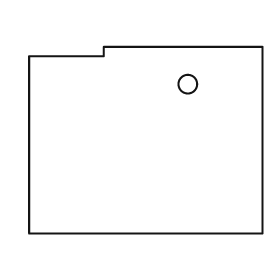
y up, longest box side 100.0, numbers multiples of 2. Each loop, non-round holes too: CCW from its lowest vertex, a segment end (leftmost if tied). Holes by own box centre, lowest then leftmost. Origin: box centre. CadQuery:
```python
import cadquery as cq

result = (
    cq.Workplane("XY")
    .moveTo(-50.0, -40.0)
    .lineTo(50.0, -40.0)
    .lineTo(50.0, 40.0)
    .lineTo(-18.0, 40.0)
    .lineTo(-18.0, 36.0)
    .lineTo(-50.0, 36.0)
    .close()
    .moveTo(18.0, 24.0)
    .circle(4.0)
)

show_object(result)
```